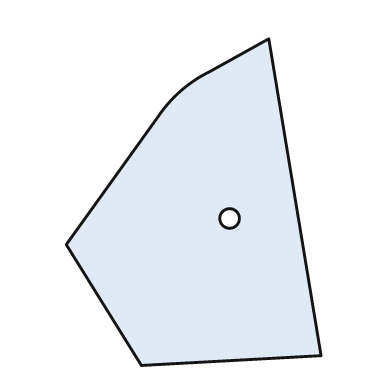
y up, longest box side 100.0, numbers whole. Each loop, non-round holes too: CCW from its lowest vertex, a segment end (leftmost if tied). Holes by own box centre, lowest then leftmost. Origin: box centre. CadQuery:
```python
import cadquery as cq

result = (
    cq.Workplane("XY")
    .moveTo(-16.0, -50.0)
    .lineTo(39.0, -47.0)
    .lineTo(23.0, 50.0)
    .lineTo(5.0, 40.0)
    .threePointArc((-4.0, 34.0), (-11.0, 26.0))
    .lineTo(-39.0, -13.0)
    .close()
    .moveTo(11.0, -5.0)
    .circle(3.0)
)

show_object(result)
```